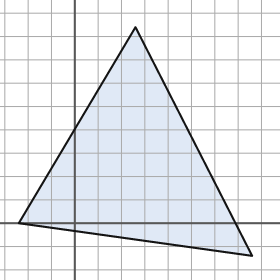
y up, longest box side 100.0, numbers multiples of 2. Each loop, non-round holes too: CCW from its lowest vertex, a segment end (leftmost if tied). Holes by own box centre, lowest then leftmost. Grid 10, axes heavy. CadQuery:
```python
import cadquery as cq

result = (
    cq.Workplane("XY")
    .moveTo(76.0, -14.0)
    .lineTo(26.0, 84.0)
    .lineTo(-24.0, 0.0)
    .close()
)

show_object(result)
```